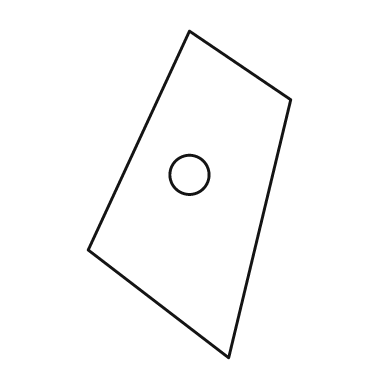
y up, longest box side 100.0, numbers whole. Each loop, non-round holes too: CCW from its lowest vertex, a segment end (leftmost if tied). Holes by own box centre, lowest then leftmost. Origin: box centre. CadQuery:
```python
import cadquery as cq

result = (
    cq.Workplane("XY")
    .moveTo(12.0, -50.0)
    .lineTo(31.0, 29.0)
    .lineTo(0.0, 50.0)
    .lineTo(-31.0, -17.0)
    .close()
    .moveTo(0.0, 6.0)
    .circle(6.0)
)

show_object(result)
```